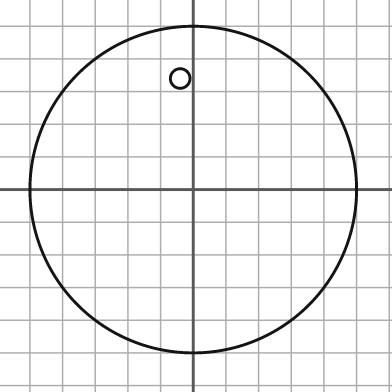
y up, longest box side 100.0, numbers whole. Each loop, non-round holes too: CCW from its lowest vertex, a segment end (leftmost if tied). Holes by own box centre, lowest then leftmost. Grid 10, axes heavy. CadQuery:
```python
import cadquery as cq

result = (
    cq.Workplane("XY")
    .moveTo(0.0, 0.0)
    .circle(50.0)
    .moveTo(-4.0, 34.0)
    .circle(3.0)
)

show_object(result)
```